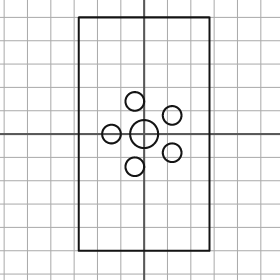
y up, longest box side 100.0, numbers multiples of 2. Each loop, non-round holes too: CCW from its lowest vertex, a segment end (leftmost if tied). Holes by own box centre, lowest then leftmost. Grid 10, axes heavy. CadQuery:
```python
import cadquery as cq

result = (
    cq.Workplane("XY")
    .moveTo(-28.0, -50.0)
    .lineTo(28.0, -50.0)
    .lineTo(28.0, 50.0)
    .lineTo(-28.0, 50.0)
    .close()
    .moveTo(-4.0, -14.0)
    .circle(4.0)
    .moveTo(12.0, -8.0)
    .circle(4.0)
    .moveTo(-14.0, 0.0)
    .circle(4.0)
    .moveTo(0.0, 0.0)
    .circle(6.0)
    .moveTo(12.0, 8.0)
    .circle(4.0)
    .moveTo(-4.0, 14.0)
    .circle(4.0)
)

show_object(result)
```